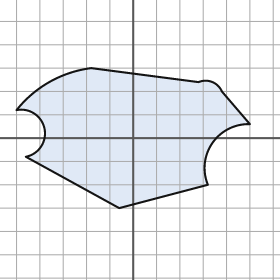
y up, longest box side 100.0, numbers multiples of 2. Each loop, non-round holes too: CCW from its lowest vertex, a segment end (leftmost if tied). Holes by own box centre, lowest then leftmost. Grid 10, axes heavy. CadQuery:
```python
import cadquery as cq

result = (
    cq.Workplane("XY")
    .moveTo(-6.0, -30.0)
    .lineTo(32.0, -20.0)
    .threePointArc((34.0, -2.0), (50.0, 6.0))
    .lineTo(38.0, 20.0)
    .threePointArc((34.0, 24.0), (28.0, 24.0))
    .lineTo(-18.0, 30.0)
    .threePointArc((-36.0, 24.0), (-50.0, 12.0))
    .threePointArc((-38.0, 4.0), (-46.0, -8.0))
    .close()
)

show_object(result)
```